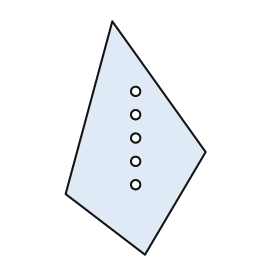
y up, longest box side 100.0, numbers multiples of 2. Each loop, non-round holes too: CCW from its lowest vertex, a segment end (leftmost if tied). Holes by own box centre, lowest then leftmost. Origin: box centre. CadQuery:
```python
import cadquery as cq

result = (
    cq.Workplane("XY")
    .moveTo(4.0, -50.0)
    .lineTo(30.0, -6.0)
    .lineTo(-10.0, 50.0)
    .lineTo(-30.0, -24.0)
    .close()
    .moveTo(0.0, -20.0)
    .circle(2.0)
    .moveTo(0.0, -10.0)
    .circle(2.0)
    .moveTo(0.0, 0.0)
    .circle(2.0)
    .moveTo(0.0, 10.0)
    .circle(2.0)
    .moveTo(0.0, 20.0)
    .circle(2.0)
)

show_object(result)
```